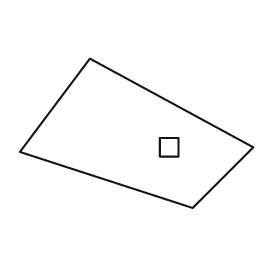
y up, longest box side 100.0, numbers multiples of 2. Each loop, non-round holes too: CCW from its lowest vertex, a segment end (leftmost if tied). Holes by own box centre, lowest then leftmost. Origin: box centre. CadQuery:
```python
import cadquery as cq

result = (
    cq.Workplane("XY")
    .moveTo(24.0, -32.0)
    .lineTo(50.0, -6.0)
    .lineTo(-20.0, 32.0)
    .lineTo(-50.0, -8.0)
    .close()
    .moveTo(10.0, -10.0)
    .lineTo(18.0, -10.0)
    .lineTo(18.0, -2.0)
    .lineTo(10.0, -2.0)
    .close()
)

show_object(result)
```